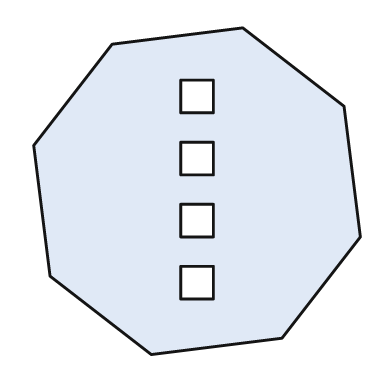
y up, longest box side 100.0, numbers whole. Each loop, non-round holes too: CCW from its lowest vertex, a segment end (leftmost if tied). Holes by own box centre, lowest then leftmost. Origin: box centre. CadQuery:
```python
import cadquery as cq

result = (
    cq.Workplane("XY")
    .moveTo(-14.0, -50.0)
    .lineTo(26.0, -45.0)
    .lineTo(50.0, -14.0)
    .lineTo(45.0, 26.0)
    .lineTo(14.0, 50.0)
    .lineTo(-26.0, 45.0)
    .lineTo(-50.0, 14.0)
    .lineTo(-45.0, -26.0)
    .close()
    .moveTo(-5.0, -33.0)
    .lineTo(5.0, -33.0)
    .lineTo(5.0, -23.0)
    .lineTo(-5.0, -23.0)
    .close()
    .moveTo(-5.0, -14.0)
    .lineTo(5.0, -14.0)
    .lineTo(5.0, -4.0)
    .lineTo(-5.0, -4.0)
    .close()
    .moveTo(-5.0, 5.0)
    .lineTo(5.0, 5.0)
    .lineTo(5.0, 15.0)
    .lineTo(-5.0, 15.0)
    .close()
    .moveTo(-5.0, 24.0)
    .lineTo(5.0, 24.0)
    .lineTo(5.0, 34.0)
    .lineTo(-5.0, 34.0)
    .close()
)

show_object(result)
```